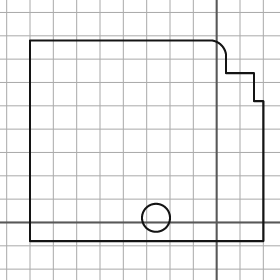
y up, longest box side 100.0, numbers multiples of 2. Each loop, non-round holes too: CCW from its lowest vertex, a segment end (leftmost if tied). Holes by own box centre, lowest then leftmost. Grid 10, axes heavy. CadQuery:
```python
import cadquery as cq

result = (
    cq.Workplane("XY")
    .moveTo(-80.0, -8.0)
    .lineTo(20.0, -8.0)
    .lineTo(20.0, 52.0)
    .lineTo(16.0, 52.0)
    .lineTo(16.0, 64.0)
    .lineTo(4.0, 64.0)
    .lineTo(4.0, 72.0)
    .threePointArc((2.0, 76.0), (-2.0, 78.0))
    .lineTo(-80.0, 78.0)
    .close()
    .moveTo(-26.0, 2.0)
    .circle(6.0)
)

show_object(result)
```